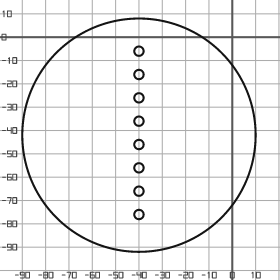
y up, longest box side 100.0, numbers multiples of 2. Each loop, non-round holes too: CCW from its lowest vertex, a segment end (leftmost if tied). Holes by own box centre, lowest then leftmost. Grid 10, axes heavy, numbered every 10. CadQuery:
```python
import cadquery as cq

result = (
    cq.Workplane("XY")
    .moveTo(-40.0, -42.0)
    .circle(50.0)
    .moveTo(-40.0, -76.0)
    .circle(2.0)
    .moveTo(-40.0, -66.0)
    .circle(2.0)
    .moveTo(-40.0, -56.0)
    .circle(2.0)
    .moveTo(-40.0, -46.0)
    .circle(2.0)
    .moveTo(-40.0, -36.0)
    .circle(2.0)
    .moveTo(-40.0, -26.0)
    .circle(2.0)
    .moveTo(-40.0, -16.0)
    .circle(2.0)
    .moveTo(-40.0, -6.0)
    .circle(2.0)
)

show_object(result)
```